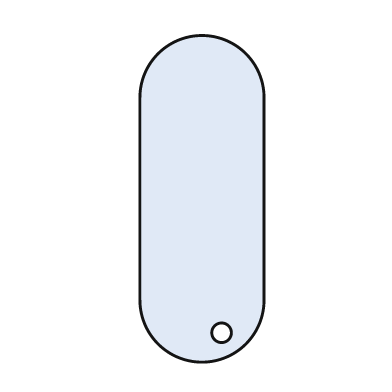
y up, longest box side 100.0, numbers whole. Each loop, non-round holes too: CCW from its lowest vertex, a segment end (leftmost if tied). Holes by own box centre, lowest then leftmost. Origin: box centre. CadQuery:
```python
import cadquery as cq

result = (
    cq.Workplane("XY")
    .moveTo(-19.0, -31.0)
    .threePointArc((0.0, -50.0), (19.0, -31.0))
    .lineTo(19.0, 31.0)
    .threePointArc((0.0, 50.0), (-19.0, 31.0))
    .close()
    .moveTo(6.0, -41.0)
    .circle(3.0)
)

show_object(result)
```